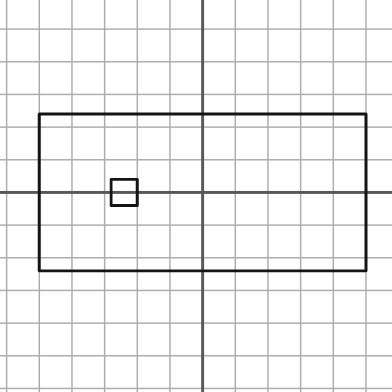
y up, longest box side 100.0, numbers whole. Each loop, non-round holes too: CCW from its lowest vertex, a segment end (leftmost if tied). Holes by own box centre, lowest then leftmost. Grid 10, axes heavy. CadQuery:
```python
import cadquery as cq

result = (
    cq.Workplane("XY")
    .moveTo(-50.0, -24.0)
    .lineTo(50.0, -24.0)
    .lineTo(50.0, 24.0)
    .lineTo(-50.0, 24.0)
    .close()
    .moveTo(-28.0, -4.0)
    .lineTo(-20.0, -4.0)
    .lineTo(-20.0, 4.0)
    .lineTo(-28.0, 4.0)
    .close()
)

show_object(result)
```